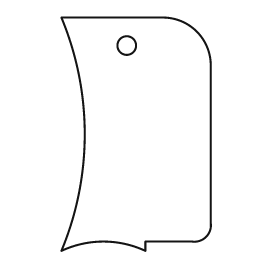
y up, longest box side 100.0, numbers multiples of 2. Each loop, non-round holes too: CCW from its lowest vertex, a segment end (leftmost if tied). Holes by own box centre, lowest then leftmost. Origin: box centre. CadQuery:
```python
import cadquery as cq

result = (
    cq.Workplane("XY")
    .moveTo(-32.0, -50.0)
    .threePointArc((-14.0, -46.0), (4.0, -50.0))
    .lineTo(4.0, -46.0)
    .lineTo(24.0, -46.0)
    .threePointArc((30.0, -44.0), (32.0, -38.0))
    .lineTo(32.0, 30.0)
    .threePointArc((26.0, 44.0), (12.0, 50.0))
    .lineTo(-32.0, 50.0)
    .threePointArc((-22.0, 0.0), (-32.0, -50.0))
    .close()
    .moveTo(-4.0, 38.0)
    .circle(4.0)
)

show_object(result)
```